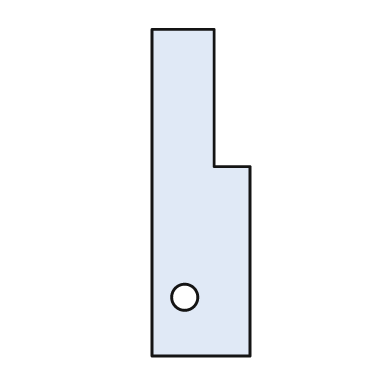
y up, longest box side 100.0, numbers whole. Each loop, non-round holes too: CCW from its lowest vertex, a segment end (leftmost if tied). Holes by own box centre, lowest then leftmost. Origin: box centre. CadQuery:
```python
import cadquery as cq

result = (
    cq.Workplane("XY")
    .moveTo(-15.0, -50.0)
    .lineTo(15.0, -50.0)
    .lineTo(15.0, 8.0)
    .lineTo(4.0, 8.0)
    .lineTo(4.0, 50.0)
    .lineTo(-15.0, 50.0)
    .close()
    .moveTo(-5.0, -32.0)
    .circle(4.0)
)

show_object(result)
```